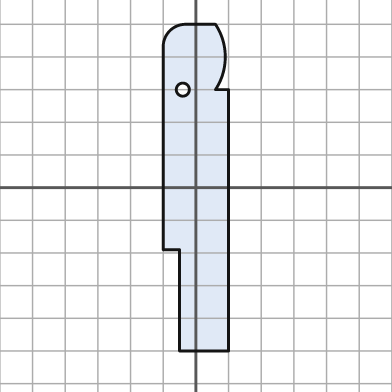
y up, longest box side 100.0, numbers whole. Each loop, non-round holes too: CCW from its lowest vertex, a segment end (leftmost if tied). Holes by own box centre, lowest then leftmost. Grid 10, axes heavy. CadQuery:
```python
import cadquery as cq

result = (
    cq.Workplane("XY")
    .moveTo(-5.0, -50.0)
    .lineTo(10.0, -50.0)
    .lineTo(10.0, 30.0)
    .lineTo(6.0, 30.0)
    .threePointArc((9.0, 40.0), (6.0, 50.0))
    .lineTo(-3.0, 50.0)
    .threePointArc((-8.0, 48.0), (-10.0, 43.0))
    .lineTo(-10.0, -19.0)
    .lineTo(-5.0, -19.0)
    .close()
    .moveTo(-4.0, 30.0)
    .circle(2.0)
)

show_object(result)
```